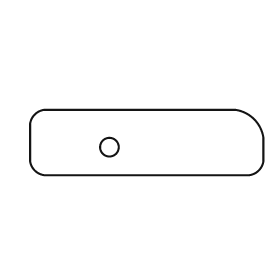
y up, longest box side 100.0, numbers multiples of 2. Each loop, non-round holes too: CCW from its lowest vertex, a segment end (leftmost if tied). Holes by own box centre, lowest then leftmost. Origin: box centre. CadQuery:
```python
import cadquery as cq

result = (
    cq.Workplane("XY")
    .moveTo(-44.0, -14.0)
    .lineTo(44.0, -14.0)
    .threePointArc((48.0, -12.0), (50.0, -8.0))
    .lineTo(50.0, 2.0)
    .threePointArc((46.0, 10.0), (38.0, 14.0))
    .lineTo(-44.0, 14.0)
    .threePointArc((-48.0, 12.0), (-50.0, 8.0))
    .lineTo(-50.0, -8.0)
    .threePointArc((-48.0, -12.0), (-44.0, -14.0))
    .close()
    .moveTo(-16.0, -2.0)
    .circle(4.0)
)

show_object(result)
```